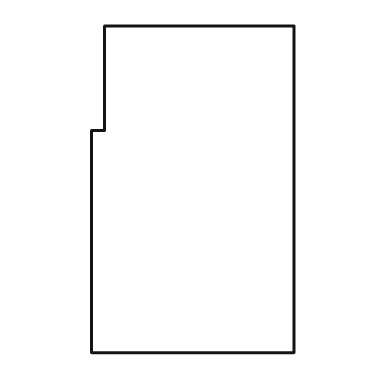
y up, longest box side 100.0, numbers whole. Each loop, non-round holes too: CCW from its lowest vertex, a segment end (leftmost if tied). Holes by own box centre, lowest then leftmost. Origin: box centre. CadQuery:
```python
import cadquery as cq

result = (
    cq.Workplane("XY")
    .moveTo(-31.0, -50.0)
    .lineTo(31.0, -50.0)
    .lineTo(31.0, 50.0)
    .lineTo(-27.0, 50.0)
    .lineTo(-27.0, 18.0)
    .lineTo(-31.0, 18.0)
    .close()
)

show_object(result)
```